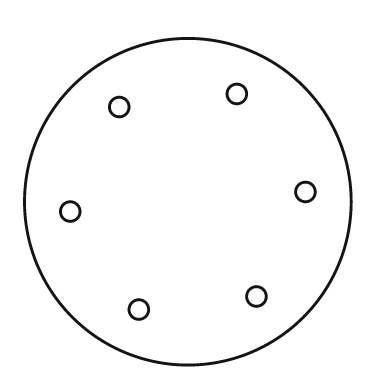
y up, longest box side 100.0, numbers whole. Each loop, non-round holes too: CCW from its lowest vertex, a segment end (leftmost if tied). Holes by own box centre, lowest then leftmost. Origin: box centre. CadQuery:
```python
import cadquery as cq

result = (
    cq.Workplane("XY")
    .moveTo(0.0, 0.0)
    .circle(50.0)
    .moveTo(-15.0, -33.0)
    .circle(3.0)
    .moveTo(21.0, -29.0)
    .circle(3.0)
    .moveTo(-36.0, -3.0)
    .circle(3.0)
    .moveTo(36.0, 3.0)
    .circle(3.0)
    .moveTo(-21.0, 29.0)
    .circle(3.0)
    .moveTo(15.0, 33.0)
    .circle(3.0)
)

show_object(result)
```